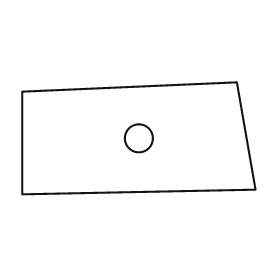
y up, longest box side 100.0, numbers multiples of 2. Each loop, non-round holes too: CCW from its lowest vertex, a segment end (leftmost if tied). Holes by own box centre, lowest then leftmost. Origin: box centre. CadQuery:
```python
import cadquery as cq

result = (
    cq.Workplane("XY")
    .moveTo(-50.0, -24.0)
    .lineTo(50.0, -22.0)
    .lineTo(42.0, 24.0)
    .lineTo(-50.0, 20.0)
    .close()
    .moveTo(0.0, 0.0)
    .circle(6.0)
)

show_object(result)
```